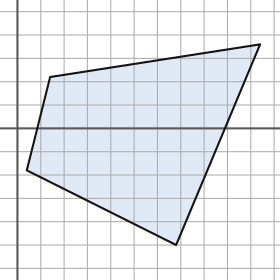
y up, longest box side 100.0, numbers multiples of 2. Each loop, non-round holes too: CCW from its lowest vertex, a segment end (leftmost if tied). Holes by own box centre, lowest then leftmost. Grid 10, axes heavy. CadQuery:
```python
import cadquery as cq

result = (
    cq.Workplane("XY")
    .moveTo(68.0, -50.0)
    .lineTo(104.0, 36.0)
    .lineTo(14.0, 22.0)
    .lineTo(4.0, -18.0)
    .close()
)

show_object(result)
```